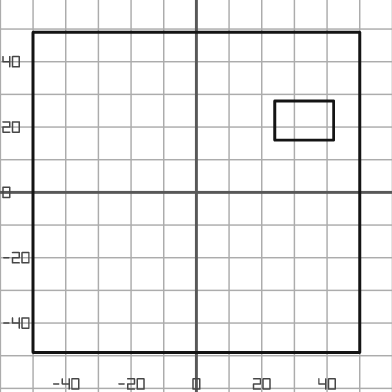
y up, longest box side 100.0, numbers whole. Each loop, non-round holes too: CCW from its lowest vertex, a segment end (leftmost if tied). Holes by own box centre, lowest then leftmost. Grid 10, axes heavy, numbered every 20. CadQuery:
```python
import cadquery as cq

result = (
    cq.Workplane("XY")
    .moveTo(-50.0, -49.0)
    .lineTo(50.0, -49.0)
    .lineTo(50.0, 49.0)
    .lineTo(-50.0, 49.0)
    .close()
    .moveTo(24.0, 16.0)
    .lineTo(42.0, 16.0)
    .lineTo(42.0, 28.0)
    .lineTo(24.0, 28.0)
    .close()
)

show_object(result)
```